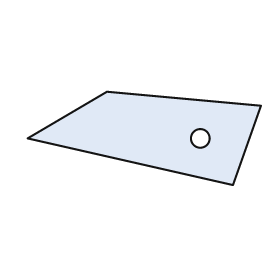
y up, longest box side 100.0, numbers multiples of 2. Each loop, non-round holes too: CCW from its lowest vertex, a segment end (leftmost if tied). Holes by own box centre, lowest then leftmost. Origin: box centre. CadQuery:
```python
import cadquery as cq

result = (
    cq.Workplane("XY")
    .moveTo(38.0, -20.0)
    .lineTo(50.0, 14.0)
    .lineTo(-16.0, 20.0)
    .lineTo(-50.0, 0.0)
    .close()
    .moveTo(24.0, 0.0)
    .circle(4.0)
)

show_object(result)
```